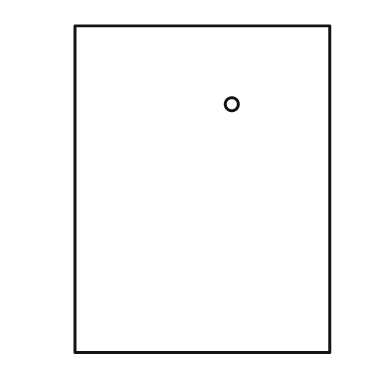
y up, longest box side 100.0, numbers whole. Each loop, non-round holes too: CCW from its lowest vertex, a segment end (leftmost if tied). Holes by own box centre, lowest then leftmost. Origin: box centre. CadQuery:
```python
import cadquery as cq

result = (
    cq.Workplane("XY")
    .moveTo(-39.0, -50.0)
    .lineTo(39.0, -50.0)
    .lineTo(39.0, 50.0)
    .lineTo(-39.0, 50.0)
    .close()
    .moveTo(9.0, 26.0)
    .circle(2.0)
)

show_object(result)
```